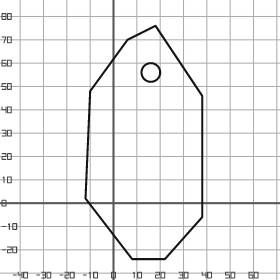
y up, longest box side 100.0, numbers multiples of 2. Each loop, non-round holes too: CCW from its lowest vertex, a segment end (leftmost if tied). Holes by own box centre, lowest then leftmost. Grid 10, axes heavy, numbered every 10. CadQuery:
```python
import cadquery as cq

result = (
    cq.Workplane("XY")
    .moveTo(8.0, -24.0)
    .lineTo(22.0, -24.0)
    .lineTo(38.0, -6.0)
    .lineTo(38.0, 46.0)
    .lineTo(18.0, 76.0)
    .lineTo(6.0, 70.0)
    .lineTo(-10.0, 48.0)
    .lineTo(-12.0, 2.0)
    .close()
    .moveTo(16.0, 56.0)
    .circle(4.0)
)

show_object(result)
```